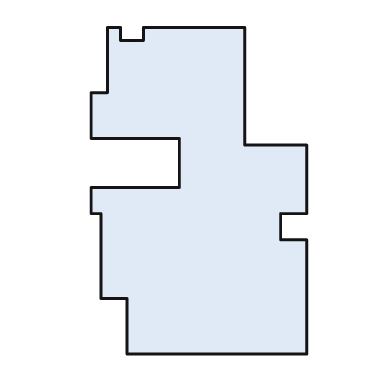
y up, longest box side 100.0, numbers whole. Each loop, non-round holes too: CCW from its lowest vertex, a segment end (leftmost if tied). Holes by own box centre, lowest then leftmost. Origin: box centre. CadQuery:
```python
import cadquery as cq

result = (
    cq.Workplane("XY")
    .moveTo(-22.0, -50.0)
    .lineTo(33.0, -50.0)
    .lineTo(33.0, -15.0)
    .lineTo(25.0, -15.0)
    .lineTo(25.0, -7.0)
    .lineTo(33.0, -7.0)
    .lineTo(33.0, 14.0)
    .lineTo(14.0, 14.0)
    .lineTo(14.0, 50.0)
    .lineTo(-17.0, 50.0)
    .lineTo(-17.0, 46.0)
    .lineTo(-24.0, 46.0)
    .lineTo(-24.0, 50.0)
    .lineTo(-28.0, 50.0)
    .lineTo(-28.0, 30.0)
    .lineTo(-33.0, 30.0)
    .lineTo(-33.0, 16.0)
    .lineTo(-6.0, 16.0)
    .lineTo(-6.0, 1.0)
    .lineTo(-33.0, 1.0)
    .lineTo(-33.0, -7.0)
    .lineTo(-30.0, -7.0)
    .lineTo(-30.0, -33.0)
    .lineTo(-22.0, -33.0)
    .close()
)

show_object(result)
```